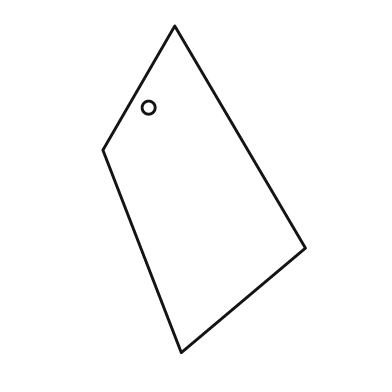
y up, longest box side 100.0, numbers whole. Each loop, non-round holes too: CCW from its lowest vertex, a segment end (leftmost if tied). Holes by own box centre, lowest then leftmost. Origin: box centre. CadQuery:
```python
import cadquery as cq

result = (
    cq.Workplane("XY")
    .moveTo(-7.0, -50.0)
    .lineTo(31.0, -18.0)
    .lineTo(-9.0, 50.0)
    .lineTo(-31.0, 12.0)
    .close()
    .moveTo(-17.0, 25.0)
    .circle(2.0)
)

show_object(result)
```